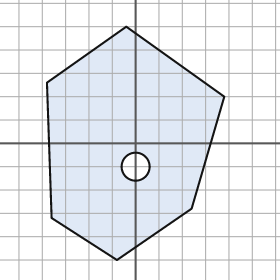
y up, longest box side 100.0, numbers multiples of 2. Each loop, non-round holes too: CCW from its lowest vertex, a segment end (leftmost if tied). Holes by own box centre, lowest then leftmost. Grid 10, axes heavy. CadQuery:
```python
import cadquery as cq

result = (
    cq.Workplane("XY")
    .moveTo(-8.0, -50.0)
    .lineTo(24.0, -28.0)
    .lineTo(38.0, 20.0)
    .lineTo(-4.0, 50.0)
    .lineTo(-38.0, 26.0)
    .lineTo(-36.0, -32.0)
    .close()
    .moveTo(0.0, -10.0)
    .circle(6.0)
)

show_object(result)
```